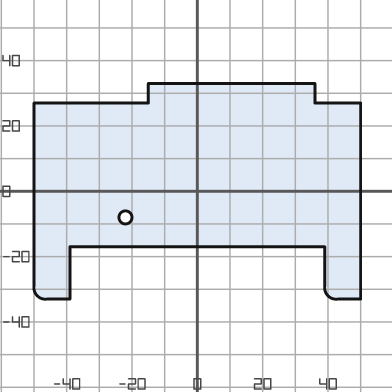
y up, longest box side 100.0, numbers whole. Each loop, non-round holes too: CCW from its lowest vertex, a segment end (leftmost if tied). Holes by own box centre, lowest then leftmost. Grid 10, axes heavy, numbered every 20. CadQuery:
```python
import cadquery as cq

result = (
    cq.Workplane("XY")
    .moveTo(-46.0, -33.0)
    .lineTo(-39.0, -33.0)
    .lineTo(-39.0, -17.0)
    .lineTo(39.0, -17.0)
    .lineTo(39.0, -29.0)
    .threePointArc((40.0, -32.0), (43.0, -33.0))
    .lineTo(50.0, -33.0)
    .lineTo(50.0, 27.0)
    .lineTo(36.0, 27.0)
    .lineTo(36.0, 33.0)
    .lineTo(-15.0, 33.0)
    .lineTo(-15.0, 27.0)
    .lineTo(-50.0, 27.0)
    .lineTo(-50.0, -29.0)
    .threePointArc((-49.0, -32.0), (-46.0, -33.0))
    .close()
    .moveTo(-22.0, -8.0)
    .circle(2.0)
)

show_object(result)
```